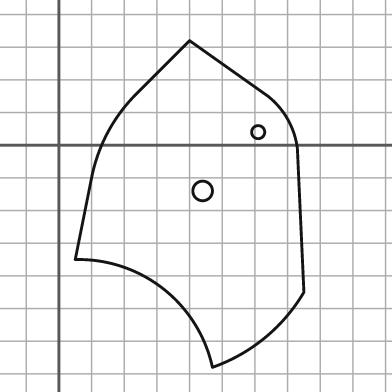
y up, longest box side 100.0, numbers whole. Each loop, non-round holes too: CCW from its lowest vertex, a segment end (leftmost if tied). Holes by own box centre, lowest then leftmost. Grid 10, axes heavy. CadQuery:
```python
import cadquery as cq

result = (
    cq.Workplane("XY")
    .moveTo(47.0, -68.0)
    .threePointArc((63.0, -59.0), (75.0, -45.0))
    .lineTo(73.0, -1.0)
    .threePointArc((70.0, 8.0), (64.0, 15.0))
    .lineTo(40.0, 32.0)
    .lineTo(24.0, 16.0)
    .threePointArc((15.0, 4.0), (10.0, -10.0))
    .lineTo(5.0, -35.0)
    .threePointArc((32.0, -44.0), (47.0, -68.0))
    .close()
    .moveTo(44.0, -14.0)
    .circle(3.0)
    .moveTo(61.0, 4.0)
    .circle(2.0)
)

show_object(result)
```